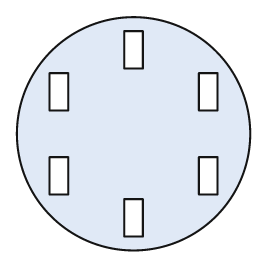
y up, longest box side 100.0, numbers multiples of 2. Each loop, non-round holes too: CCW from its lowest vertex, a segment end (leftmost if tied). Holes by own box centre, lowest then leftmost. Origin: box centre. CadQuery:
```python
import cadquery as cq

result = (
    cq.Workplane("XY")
    .moveTo(0.0, 0.0)
    .circle(50.0)
    .moveTo(-4.0, -44.0)
    .lineTo(4.0, -44.0)
    .lineTo(4.0, -28.0)
    .lineTo(-4.0, -28.0)
    .close()
    .moveTo(-36.0, -26.0)
    .lineTo(-28.0, -26.0)
    .lineTo(-28.0, -10.0)
    .lineTo(-36.0, -10.0)
    .close()
    .moveTo(28.0, -26.0)
    .lineTo(36.0, -26.0)
    .lineTo(36.0, -10.0)
    .lineTo(28.0, -10.0)
    .close()
    .moveTo(-36.0, 10.0)
    .lineTo(-28.0, 10.0)
    .lineTo(-28.0, 26.0)
    .lineTo(-36.0, 26.0)
    .close()
    .moveTo(28.0, 10.0)
    .lineTo(36.0, 10.0)
    .lineTo(36.0, 26.0)
    .lineTo(28.0, 26.0)
    .close()
    .moveTo(-4.0, 28.0)
    .lineTo(4.0, 28.0)
    .lineTo(4.0, 44.0)
    .lineTo(-4.0, 44.0)
    .close()
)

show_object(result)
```